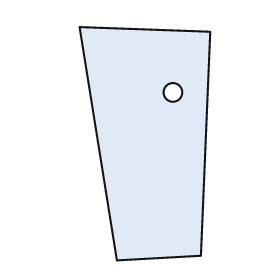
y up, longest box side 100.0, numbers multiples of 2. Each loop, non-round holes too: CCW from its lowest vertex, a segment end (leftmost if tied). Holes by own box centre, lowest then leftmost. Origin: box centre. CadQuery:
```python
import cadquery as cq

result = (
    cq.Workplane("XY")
    .moveTo(-12.0, -50.0)
    .lineTo(24.0, -48.0)
    .lineTo(28.0, 48.0)
    .lineTo(-28.0, 50.0)
    .close()
    .moveTo(12.0, 22.0)
    .circle(4.0)
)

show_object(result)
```